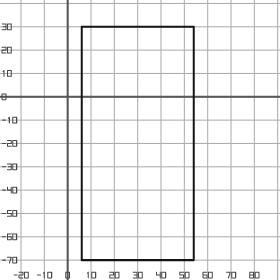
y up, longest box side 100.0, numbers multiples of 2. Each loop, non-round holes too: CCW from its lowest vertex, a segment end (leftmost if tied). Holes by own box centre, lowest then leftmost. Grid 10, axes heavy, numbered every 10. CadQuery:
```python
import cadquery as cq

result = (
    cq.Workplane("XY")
    .moveTo(6.0, -70.0)
    .lineTo(54.0, -70.0)
    .lineTo(54.0, 30.0)
    .lineTo(6.0, 30.0)
    .close()
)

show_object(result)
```